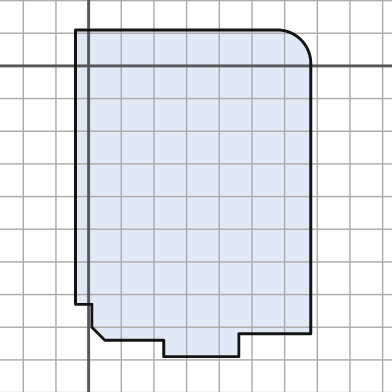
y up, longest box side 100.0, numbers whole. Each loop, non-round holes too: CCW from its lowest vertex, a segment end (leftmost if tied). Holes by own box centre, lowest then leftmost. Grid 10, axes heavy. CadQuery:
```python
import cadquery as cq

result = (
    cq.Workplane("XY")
    .moveTo(23.0, -89.0)
    .lineTo(46.0, -89.0)
    .lineTo(46.0, -82.0)
    .lineTo(68.0, -82.0)
    .lineTo(68.0, 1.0)
    .threePointArc((65.0, 8.0), (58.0, 11.0))
    .lineTo(-4.0, 11.0)
    .lineTo(-4.0, -73.0)
    .lineTo(1.0, -73.0)
    .lineTo(1.0, -80.0)
    .lineTo(5.0, -84.0)
    .lineTo(23.0, -84.0)
    .close()
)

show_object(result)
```